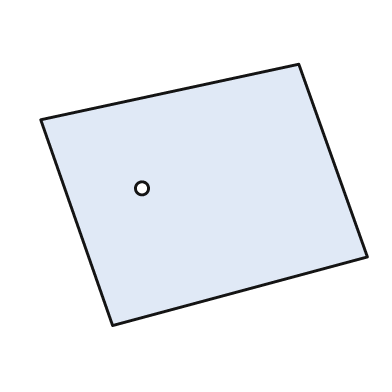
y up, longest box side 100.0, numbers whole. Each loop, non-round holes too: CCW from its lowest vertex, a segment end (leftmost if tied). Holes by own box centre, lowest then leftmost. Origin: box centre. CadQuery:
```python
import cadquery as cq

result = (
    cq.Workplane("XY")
    .moveTo(-28.0, -40.0)
    .lineTo(50.0, -19.0)
    .lineTo(29.0, 40.0)
    .lineTo(-50.0, 23.0)
    .close()
    .moveTo(-19.0, 2.0)
    .circle(2.0)
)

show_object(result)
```